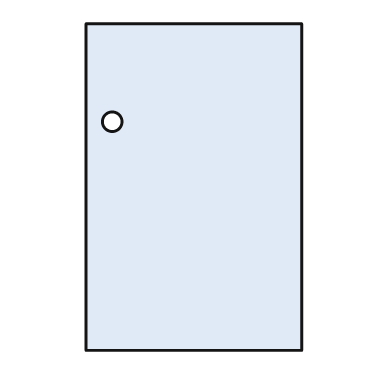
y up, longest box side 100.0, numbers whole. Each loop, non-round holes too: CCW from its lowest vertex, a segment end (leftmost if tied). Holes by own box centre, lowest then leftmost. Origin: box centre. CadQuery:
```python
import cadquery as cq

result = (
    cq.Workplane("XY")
    .moveTo(-33.0, -50.0)
    .lineTo(33.0, -50.0)
    .lineTo(33.0, 50.0)
    .lineTo(-33.0, 50.0)
    .close()
    .moveTo(-25.0, 20.0)
    .circle(3.0)
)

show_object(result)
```